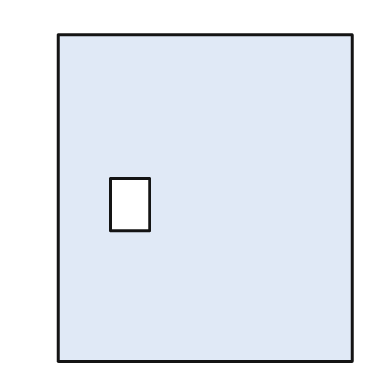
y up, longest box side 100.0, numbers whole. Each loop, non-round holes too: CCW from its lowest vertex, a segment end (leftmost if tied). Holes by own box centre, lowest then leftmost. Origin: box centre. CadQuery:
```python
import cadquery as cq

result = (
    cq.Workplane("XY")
    .moveTo(-45.0, -50.0)
    .lineTo(45.0, -50.0)
    .lineTo(45.0, 50.0)
    .lineTo(-45.0, 50.0)
    .close()
    .moveTo(-29.0, -10.0)
    .lineTo(-17.0, -10.0)
    .lineTo(-17.0, 6.0)
    .lineTo(-29.0, 6.0)
    .close()
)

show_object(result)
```